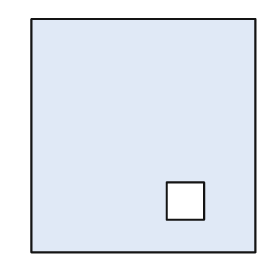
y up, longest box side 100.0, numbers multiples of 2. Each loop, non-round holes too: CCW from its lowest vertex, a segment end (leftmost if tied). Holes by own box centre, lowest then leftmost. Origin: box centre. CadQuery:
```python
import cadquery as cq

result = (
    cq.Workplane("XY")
    .moveTo(-48.0, -50.0)
    .lineTo(48.0, -50.0)
    .lineTo(48.0, 50.0)
    .lineTo(-48.0, 50.0)
    .close()
    .moveTo(10.0, -36.0)
    .lineTo(26.0, -36.0)
    .lineTo(26.0, -20.0)
    .lineTo(10.0, -20.0)
    .close()
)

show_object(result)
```